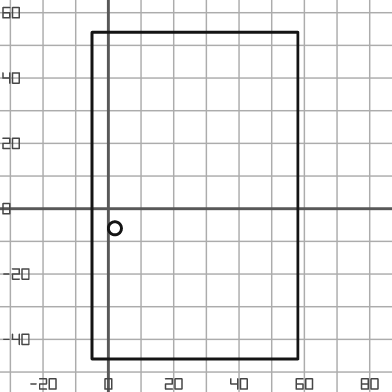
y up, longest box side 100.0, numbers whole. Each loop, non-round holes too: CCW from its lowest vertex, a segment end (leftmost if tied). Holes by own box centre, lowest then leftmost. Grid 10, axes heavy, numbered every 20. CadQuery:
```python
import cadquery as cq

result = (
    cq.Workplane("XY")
    .moveTo(-5.0, -46.0)
    .lineTo(58.0, -46.0)
    .lineTo(58.0, 54.0)
    .lineTo(-5.0, 54.0)
    .close()
    .moveTo(2.0, -6.0)
    .circle(2.0)
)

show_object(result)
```